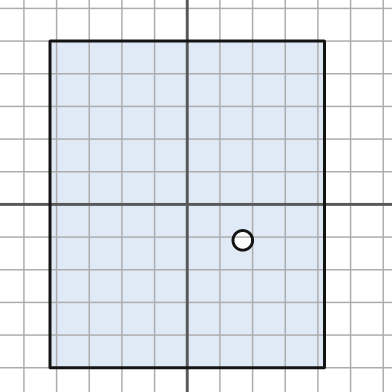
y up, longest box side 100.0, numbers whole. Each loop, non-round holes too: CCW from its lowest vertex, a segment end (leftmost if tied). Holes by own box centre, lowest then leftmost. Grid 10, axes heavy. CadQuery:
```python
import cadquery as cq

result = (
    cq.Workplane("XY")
    .moveTo(-42.0, -50.0)
    .lineTo(42.0, -50.0)
    .lineTo(42.0, 50.0)
    .lineTo(-42.0, 50.0)
    .close()
    .moveTo(17.0, -11.0)
    .circle(3.0)
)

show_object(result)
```